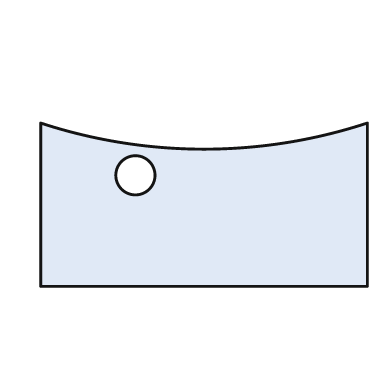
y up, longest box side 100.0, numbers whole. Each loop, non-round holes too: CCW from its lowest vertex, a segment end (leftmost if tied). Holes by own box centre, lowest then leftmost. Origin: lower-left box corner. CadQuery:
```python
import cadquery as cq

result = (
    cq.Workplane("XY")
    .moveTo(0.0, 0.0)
    .lineTo(100.0, 0.0)
    .lineTo(100.0, 50.0)
    .threePointArc((50.0, 42.0), (0.0, 50.0))
    .close()
    .moveTo(29.0, 34.0)
    .circle(6.0)
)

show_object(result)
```